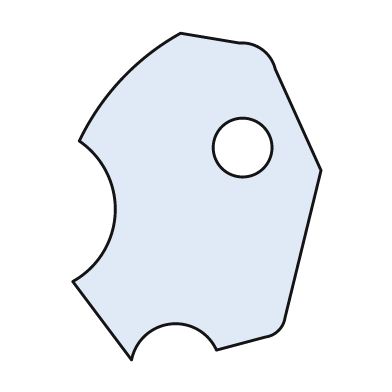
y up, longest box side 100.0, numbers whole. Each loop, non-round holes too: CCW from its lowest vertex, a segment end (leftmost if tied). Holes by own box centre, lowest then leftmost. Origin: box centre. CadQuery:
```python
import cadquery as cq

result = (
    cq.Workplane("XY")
    .moveTo(-20.0, -50.0)
    .threePointArc((-8.0, -39.0), (6.0, -47.0))
    .lineTo(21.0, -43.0)
    .threePointArc((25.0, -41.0), (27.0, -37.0))
    .lineTo(38.0, 8.0)
    .lineTo(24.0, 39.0)
    .threePointArc((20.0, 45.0), (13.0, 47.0))
    .lineTo(-5.0, 50.0)
    .threePointArc((-23.0, 36.0), (-36.0, 17.0))
    .threePointArc((-25.0, -5.0), (-38.0, -26.0))
    .close()
    .moveTo(14.0, 15.0)
    .circle(9.0)
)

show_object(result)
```